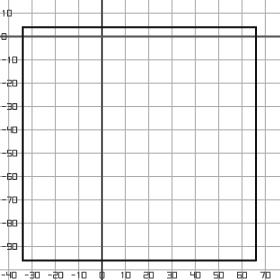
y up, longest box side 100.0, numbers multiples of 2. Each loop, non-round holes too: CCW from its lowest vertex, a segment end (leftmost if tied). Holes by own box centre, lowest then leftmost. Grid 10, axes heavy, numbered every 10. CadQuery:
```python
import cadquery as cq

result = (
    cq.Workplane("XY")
    .moveTo(-34.0, -96.0)
    .lineTo(66.0, -96.0)
    .lineTo(66.0, 4.0)
    .lineTo(-34.0, 4.0)
    .close()
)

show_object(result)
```